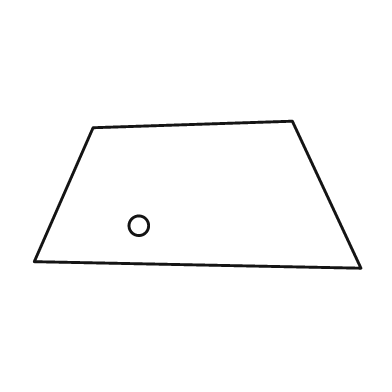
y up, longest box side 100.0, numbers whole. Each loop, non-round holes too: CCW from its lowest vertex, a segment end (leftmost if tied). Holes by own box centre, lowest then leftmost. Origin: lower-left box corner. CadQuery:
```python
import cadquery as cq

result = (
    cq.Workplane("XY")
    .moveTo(100.0, 0.0)
    .lineTo(79.0, 45.0)
    .lineTo(18.0, 43.0)
    .lineTo(0.0, 2.0)
    .close()
    .moveTo(32.0, 13.0)
    .circle(3.0)
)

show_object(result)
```